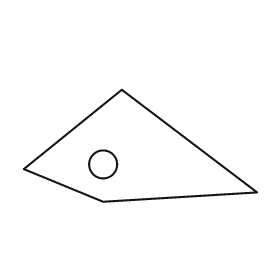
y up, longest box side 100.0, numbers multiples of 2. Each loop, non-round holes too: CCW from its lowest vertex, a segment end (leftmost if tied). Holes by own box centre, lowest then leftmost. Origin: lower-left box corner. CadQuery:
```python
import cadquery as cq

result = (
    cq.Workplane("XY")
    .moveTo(34.0, 0.0)
    .lineTo(100.0, 4.0)
    .lineTo(42.0, 48.0)
    .lineTo(0.0, 14.0)
    .close()
    .moveTo(34.0, 16.0)
    .circle(6.0)
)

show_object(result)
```